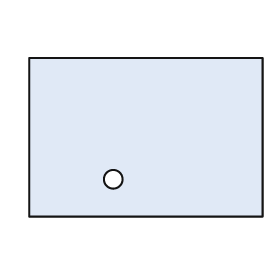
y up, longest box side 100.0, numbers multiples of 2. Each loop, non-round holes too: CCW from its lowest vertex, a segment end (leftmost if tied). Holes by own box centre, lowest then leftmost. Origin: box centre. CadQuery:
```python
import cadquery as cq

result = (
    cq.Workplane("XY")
    .moveTo(-50.0, -34.0)
    .lineTo(50.0, -34.0)
    .lineTo(50.0, 34.0)
    .lineTo(-50.0, 34.0)
    .close()
    .moveTo(-14.0, -18.0)
    .circle(4.0)
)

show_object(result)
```